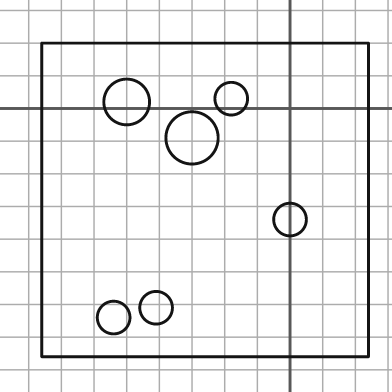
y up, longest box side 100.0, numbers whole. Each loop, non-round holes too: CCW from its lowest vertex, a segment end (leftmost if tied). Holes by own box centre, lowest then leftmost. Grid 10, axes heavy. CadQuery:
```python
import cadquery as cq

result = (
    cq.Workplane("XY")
    .moveTo(-76.0, -76.0)
    .lineTo(24.0, -76.0)
    .lineTo(24.0, 20.0)
    .lineTo(-76.0, 20.0)
    .close()
    .moveTo(-54.0, -64.0)
    .circle(5.0)
    .moveTo(-41.0, -61.0)
    .circle(5.0)
    .moveTo(0.0, -34.0)
    .circle(5.0)
    .moveTo(-30.0, -9.0)
    .circle(8.0)
    .moveTo(-50.0, 2.0)
    .circle(7.0)
    .moveTo(-18.0, 3.0)
    .circle(5.0)
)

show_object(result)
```